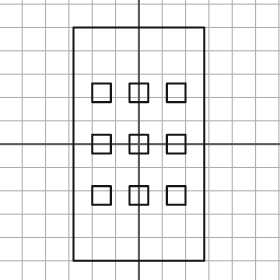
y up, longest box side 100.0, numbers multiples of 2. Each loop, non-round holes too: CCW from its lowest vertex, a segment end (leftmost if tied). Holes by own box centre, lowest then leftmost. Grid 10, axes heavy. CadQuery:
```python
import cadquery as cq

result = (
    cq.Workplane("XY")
    .moveTo(-28.0, -50.0)
    .lineTo(28.0, -50.0)
    .lineTo(28.0, 50.0)
    .lineTo(-28.0, 50.0)
    .close()
    .moveTo(-20.0, -26.0)
    .lineTo(-12.0, -26.0)
    .lineTo(-12.0, -18.0)
    .lineTo(-20.0, -18.0)
    .close()
    .moveTo(-4.0, -26.0)
    .lineTo(4.0, -26.0)
    .lineTo(4.0, -18.0)
    .lineTo(-4.0, -18.0)
    .close()
    .moveTo(12.0, -26.0)
    .lineTo(20.0, -26.0)
    .lineTo(20.0, -18.0)
    .lineTo(12.0, -18.0)
    .close()
    .moveTo(-20.0, -4.0)
    .lineTo(-12.0, -4.0)
    .lineTo(-12.0, 4.0)
    .lineTo(-20.0, 4.0)
    .close()
    .moveTo(-4.0, -4.0)
    .lineTo(4.0, -4.0)
    .lineTo(4.0, 4.0)
    .lineTo(-4.0, 4.0)
    .close()
    .moveTo(12.0, -4.0)
    .lineTo(20.0, -4.0)
    .lineTo(20.0, 4.0)
    .lineTo(12.0, 4.0)
    .close()
    .moveTo(-20.0, 18.0)
    .lineTo(-12.0, 18.0)
    .lineTo(-12.0, 26.0)
    .lineTo(-20.0, 26.0)
    .close()
    .moveTo(-4.0, 18.0)
    .lineTo(4.0, 18.0)
    .lineTo(4.0, 26.0)
    .lineTo(-4.0, 26.0)
    .close()
    .moveTo(12.0, 18.0)
    .lineTo(20.0, 18.0)
    .lineTo(20.0, 26.0)
    .lineTo(12.0, 26.0)
    .close()
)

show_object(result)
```